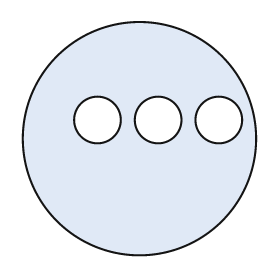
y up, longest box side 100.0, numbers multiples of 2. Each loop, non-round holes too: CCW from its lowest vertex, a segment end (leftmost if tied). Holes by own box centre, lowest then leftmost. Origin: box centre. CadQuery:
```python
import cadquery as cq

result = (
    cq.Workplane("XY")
    .moveTo(0.0, 0.0)
    .circle(50.0)
    .moveTo(-18.0, 8.0)
    .circle(10.0)
    .moveTo(8.0, 8.0)
    .circle(10.0)
    .moveTo(34.0, 8.0)
    .circle(10.0)
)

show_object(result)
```